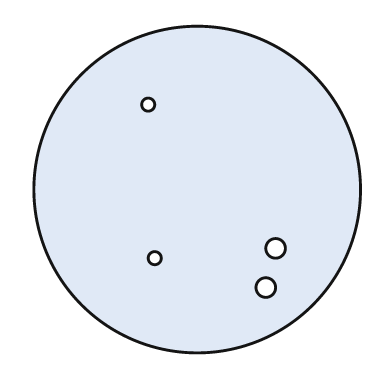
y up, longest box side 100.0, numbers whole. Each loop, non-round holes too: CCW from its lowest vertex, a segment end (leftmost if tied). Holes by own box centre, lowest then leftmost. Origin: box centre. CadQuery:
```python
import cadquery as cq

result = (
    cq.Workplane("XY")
    .moveTo(0.0, 0.0)
    .circle(50.0)
    .moveTo(21.0, -30.0)
    .circle(3.0)
    .moveTo(-13.0, -21.0)
    .circle(2.0)
    .moveTo(24.0, -18.0)
    .circle(3.0)
    .moveTo(-15.0, 26.0)
    .circle(2.0)
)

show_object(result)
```